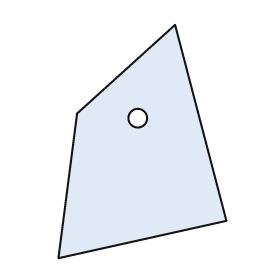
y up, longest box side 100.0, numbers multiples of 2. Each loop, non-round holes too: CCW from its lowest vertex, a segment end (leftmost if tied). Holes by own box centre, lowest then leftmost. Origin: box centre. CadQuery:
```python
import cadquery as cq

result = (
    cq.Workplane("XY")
    .moveTo(-36.0, -50.0)
    .lineTo(36.0, -34.0)
    .lineTo(14.0, 50.0)
    .lineTo(-28.0, 12.0)
    .close()
    .moveTo(-2.0, 10.0)
    .circle(4.0)
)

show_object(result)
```